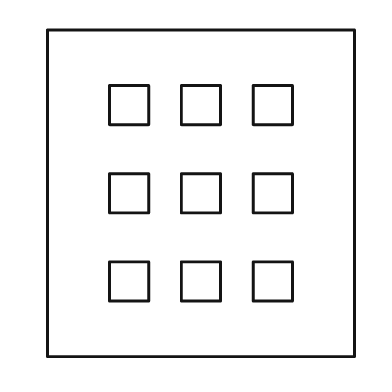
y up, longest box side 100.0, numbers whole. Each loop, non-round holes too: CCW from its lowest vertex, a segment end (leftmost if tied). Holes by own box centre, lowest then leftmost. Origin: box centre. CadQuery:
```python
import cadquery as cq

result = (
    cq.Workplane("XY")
    .moveTo(-47.0, -50.0)
    .lineTo(47.0, -50.0)
    .lineTo(47.0, 50.0)
    .lineTo(-47.0, 50.0)
    .close()
    .moveTo(-28.0, -33.0)
    .lineTo(-16.0, -33.0)
    .lineTo(-16.0, -21.0)
    .lineTo(-28.0, -21.0)
    .close()
    .moveTo(-6.0, -33.0)
    .lineTo(6.0, -33.0)
    .lineTo(6.0, -21.0)
    .lineTo(-6.0, -21.0)
    .close()
    .moveTo(16.0, -33.0)
    .lineTo(28.0, -33.0)
    .lineTo(28.0, -21.0)
    .lineTo(16.0, -21.0)
    .close()
    .moveTo(-28.0, -6.0)
    .lineTo(-16.0, -6.0)
    .lineTo(-16.0, 6.0)
    .lineTo(-28.0, 6.0)
    .close()
    .moveTo(-6.0, -6.0)
    .lineTo(6.0, -6.0)
    .lineTo(6.0, 6.0)
    .lineTo(-6.0, 6.0)
    .close()
    .moveTo(16.0, -6.0)
    .lineTo(28.0, -6.0)
    .lineTo(28.0, 6.0)
    .lineTo(16.0, 6.0)
    .close()
    .moveTo(-28.0, 21.0)
    .lineTo(-16.0, 21.0)
    .lineTo(-16.0, 33.0)
    .lineTo(-28.0, 33.0)
    .close()
    .moveTo(-6.0, 21.0)
    .lineTo(6.0, 21.0)
    .lineTo(6.0, 33.0)
    .lineTo(-6.0, 33.0)
    .close()
    .moveTo(16.0, 21.0)
    .lineTo(28.0, 21.0)
    .lineTo(28.0, 33.0)
    .lineTo(16.0, 33.0)
    .close()
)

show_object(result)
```